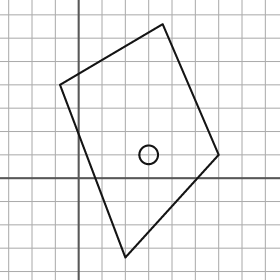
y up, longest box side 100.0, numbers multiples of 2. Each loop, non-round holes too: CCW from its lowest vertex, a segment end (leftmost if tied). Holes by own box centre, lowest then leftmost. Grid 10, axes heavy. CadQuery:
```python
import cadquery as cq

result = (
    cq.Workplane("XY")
    .moveTo(20.0, -34.0)
    .lineTo(60.0, 10.0)
    .lineTo(36.0, 66.0)
    .lineTo(-8.0, 40.0)
    .close()
    .moveTo(30.0, 10.0)
    .circle(4.0)
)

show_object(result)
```